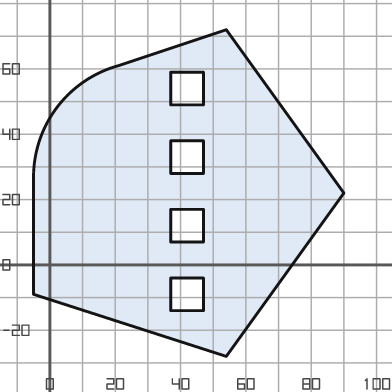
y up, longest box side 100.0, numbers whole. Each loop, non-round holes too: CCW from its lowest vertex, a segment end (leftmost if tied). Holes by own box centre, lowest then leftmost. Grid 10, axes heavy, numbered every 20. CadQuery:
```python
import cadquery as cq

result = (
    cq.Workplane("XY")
    .moveTo(54.0, -28.0)
    .lineTo(90.0, 22.0)
    .lineTo(54.0, 72.0)
    .lineTo(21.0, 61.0)
    .threePointArc((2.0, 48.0), (-5.0, 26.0))
    .lineTo(-5.0, -9.0)
    .close()
    .moveTo(37.0, -14.0)
    .lineTo(47.0, -14.0)
    .lineTo(47.0, -4.0)
    .lineTo(37.0, -4.0)
    .close()
    .moveTo(37.0, 7.0)
    .lineTo(47.0, 7.0)
    .lineTo(47.0, 17.0)
    .lineTo(37.0, 17.0)
    .close()
    .moveTo(37.0, 28.0)
    .lineTo(47.0, 28.0)
    .lineTo(47.0, 38.0)
    .lineTo(37.0, 38.0)
    .close()
    .moveTo(37.0, 49.0)
    .lineTo(47.0, 49.0)
    .lineTo(47.0, 59.0)
    .lineTo(37.0, 59.0)
    .close()
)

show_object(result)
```